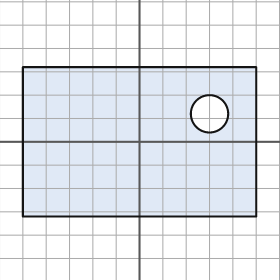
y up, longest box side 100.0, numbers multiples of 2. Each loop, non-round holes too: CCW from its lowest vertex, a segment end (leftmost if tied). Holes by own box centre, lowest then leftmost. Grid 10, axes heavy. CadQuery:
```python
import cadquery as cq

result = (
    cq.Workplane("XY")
    .moveTo(-50.0, -32.0)
    .lineTo(50.0, -32.0)
    .lineTo(50.0, 32.0)
    .lineTo(-50.0, 32.0)
    .close()
    .moveTo(30.0, 12.0)
    .circle(8.0)
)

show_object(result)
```